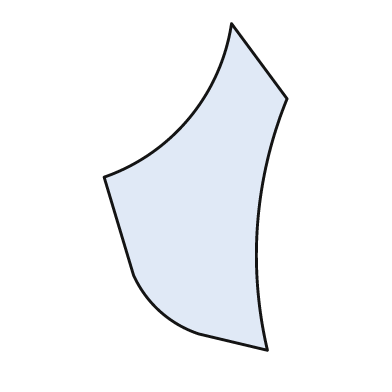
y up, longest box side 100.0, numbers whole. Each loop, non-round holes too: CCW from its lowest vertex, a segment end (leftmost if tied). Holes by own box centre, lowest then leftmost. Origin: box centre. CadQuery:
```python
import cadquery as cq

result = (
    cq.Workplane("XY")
    .moveTo(22.0, -50.0)
    .threePointArc((19.0, -11.0), (28.0, 27.0))
    .lineTo(11.0, 50.0)
    .threePointArc((-2.0, 21.0), (-28.0, 3.0))
    .lineTo(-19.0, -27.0)
    .threePointArc((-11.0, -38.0), (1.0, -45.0))
    .close()
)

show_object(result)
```